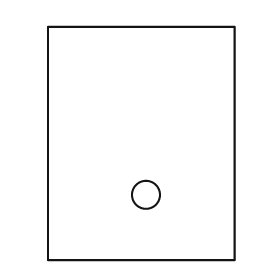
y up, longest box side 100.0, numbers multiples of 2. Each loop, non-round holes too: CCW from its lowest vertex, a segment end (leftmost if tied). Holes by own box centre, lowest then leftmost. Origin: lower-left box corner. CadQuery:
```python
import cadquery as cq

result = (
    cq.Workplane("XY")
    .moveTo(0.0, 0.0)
    .lineTo(80.0, 0.0)
    .lineTo(80.0, 100.0)
    .lineTo(0.0, 100.0)
    .close()
    .moveTo(42.0, 28.0)
    .circle(6.0)
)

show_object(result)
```